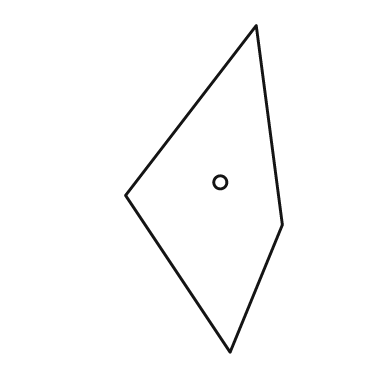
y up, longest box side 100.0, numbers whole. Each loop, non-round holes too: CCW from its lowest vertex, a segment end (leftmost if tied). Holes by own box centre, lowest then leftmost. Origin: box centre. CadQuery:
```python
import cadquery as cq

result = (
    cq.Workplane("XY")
    .moveTo(8.0, -50.0)
    .lineTo(24.0, -11.0)
    .lineTo(16.0, 50.0)
    .lineTo(-24.0, -2.0)
    .close()
    .moveTo(5.0, 2.0)
    .circle(2.0)
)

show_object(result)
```